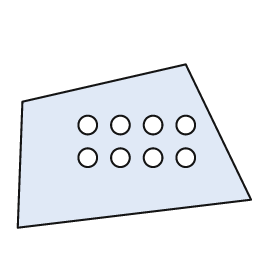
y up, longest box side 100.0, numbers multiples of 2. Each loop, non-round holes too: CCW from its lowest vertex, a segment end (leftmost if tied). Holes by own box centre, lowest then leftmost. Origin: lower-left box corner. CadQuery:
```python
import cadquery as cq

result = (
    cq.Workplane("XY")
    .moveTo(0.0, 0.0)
    .lineTo(100.0, 12.0)
    .lineTo(72.0, 70.0)
    .lineTo(2.0, 54.0)
    .close()
    .moveTo(30.0, 30.0)
    .circle(4.0)
    .moveTo(44.0, 30.0)
    .circle(4.0)
    .moveTo(58.0, 30.0)
    .circle(4.0)
    .moveTo(72.0, 30.0)
    .circle(4.0)
    .moveTo(30.0, 44.0)
    .circle(4.0)
    .moveTo(44.0, 44.0)
    .circle(4.0)
    .moveTo(58.0, 44.0)
    .circle(4.0)
    .moveTo(72.0, 44.0)
    .circle(4.0)
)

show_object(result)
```